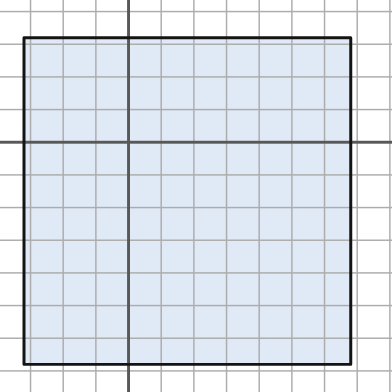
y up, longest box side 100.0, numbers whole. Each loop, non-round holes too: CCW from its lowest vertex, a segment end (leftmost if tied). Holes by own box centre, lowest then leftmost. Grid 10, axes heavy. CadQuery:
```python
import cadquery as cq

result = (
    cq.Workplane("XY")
    .moveTo(-32.0, -68.0)
    .lineTo(68.0, -68.0)
    .lineTo(68.0, 32.0)
    .lineTo(-32.0, 32.0)
    .close()
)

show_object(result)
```